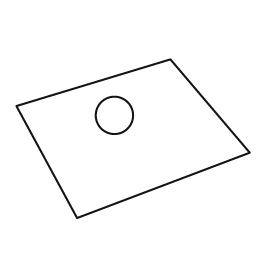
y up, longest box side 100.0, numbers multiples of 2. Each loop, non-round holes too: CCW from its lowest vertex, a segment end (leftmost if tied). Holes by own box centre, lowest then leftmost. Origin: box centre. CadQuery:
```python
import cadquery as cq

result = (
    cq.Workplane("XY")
    .moveTo(-24.0, -34.0)
    .lineTo(50.0, -6.0)
    .lineTo(16.0, 34.0)
    .lineTo(-50.0, 14.0)
    .close()
    .moveTo(-8.0, 10.0)
    .circle(8.0)
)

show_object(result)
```